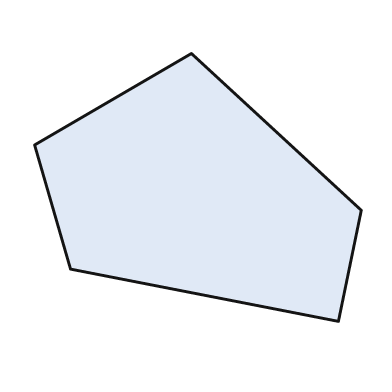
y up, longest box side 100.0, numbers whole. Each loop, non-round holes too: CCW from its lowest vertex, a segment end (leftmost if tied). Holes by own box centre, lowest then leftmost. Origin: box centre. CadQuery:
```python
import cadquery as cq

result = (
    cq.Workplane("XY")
    .moveTo(43.0, -41.0)
    .lineTo(50.0, -7.0)
    .lineTo(-2.0, 41.0)
    .lineTo(-50.0, 13.0)
    .lineTo(-39.0, -25.0)
    .close()
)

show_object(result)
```